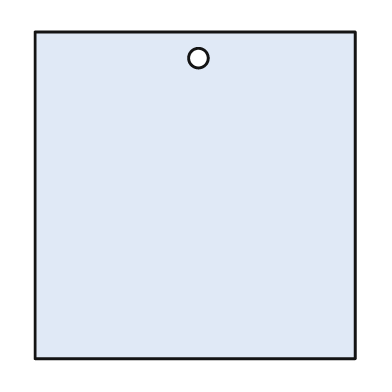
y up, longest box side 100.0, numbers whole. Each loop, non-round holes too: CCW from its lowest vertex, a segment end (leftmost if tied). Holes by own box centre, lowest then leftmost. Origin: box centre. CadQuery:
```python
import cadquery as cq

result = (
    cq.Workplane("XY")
    .moveTo(-49.0, -50.0)
    .lineTo(49.0, -50.0)
    .lineTo(49.0, 50.0)
    .lineTo(-49.0, 50.0)
    .close()
    .moveTo(1.0, 42.0)
    .circle(3.0)
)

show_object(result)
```